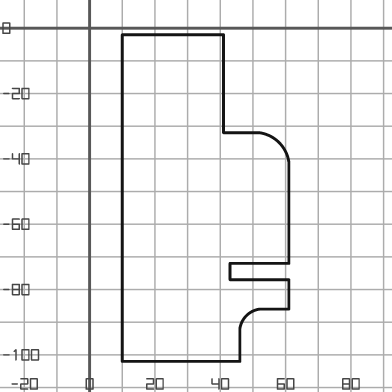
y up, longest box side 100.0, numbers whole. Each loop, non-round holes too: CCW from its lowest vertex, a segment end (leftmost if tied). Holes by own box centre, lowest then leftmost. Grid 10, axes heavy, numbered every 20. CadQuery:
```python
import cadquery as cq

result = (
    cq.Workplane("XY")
    .moveTo(10.0, -102.0)
    .lineTo(46.0, -102.0)
    .lineTo(46.0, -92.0)
    .threePointArc((48.0, -88.0), (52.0, -86.0))
    .lineTo(61.0, -86.0)
    .lineTo(61.0, -77.0)
    .lineTo(43.0, -77.0)
    .lineTo(43.0, -72.0)
    .lineTo(61.0, -72.0)
    .lineTo(61.0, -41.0)
    .threePointArc((58.0, -35.0), (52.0, -32.0))
    .lineTo(41.0, -32.0)
    .lineTo(41.0, -2.0)
    .lineTo(10.0, -2.0)
    .close()
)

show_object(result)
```